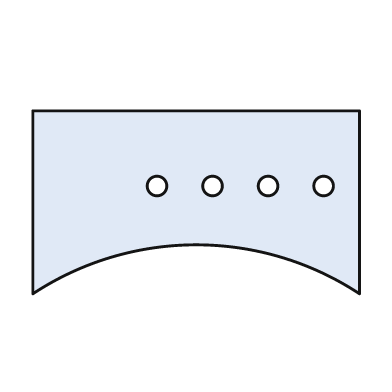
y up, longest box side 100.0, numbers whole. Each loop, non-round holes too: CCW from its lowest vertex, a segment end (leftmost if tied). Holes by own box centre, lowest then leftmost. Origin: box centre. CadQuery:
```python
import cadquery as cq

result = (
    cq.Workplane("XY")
    .moveTo(-50.0, -28.0)
    .threePointArc((0.0, -13.0), (50.0, -28.0))
    .lineTo(50.0, 28.0)
    .lineTo(-50.0, 28.0)
    .close()
    .moveTo(-12.0, 5.0)
    .circle(3.0)
    .moveTo(5.0, 5.0)
    .circle(3.0)
    .moveTo(22.0, 5.0)
    .circle(3.0)
    .moveTo(39.0, 5.0)
    .circle(3.0)
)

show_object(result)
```